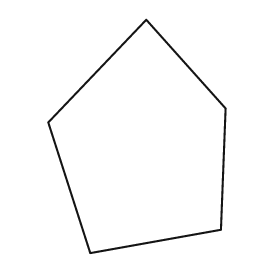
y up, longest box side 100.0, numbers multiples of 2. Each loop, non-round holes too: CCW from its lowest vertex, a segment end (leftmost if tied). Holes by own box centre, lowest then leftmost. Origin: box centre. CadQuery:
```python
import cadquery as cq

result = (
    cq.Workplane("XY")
    .moveTo(-20.0, -50.0)
    .lineTo(36.0, -40.0)
    .lineTo(38.0, 12.0)
    .lineTo(4.0, 50.0)
    .lineTo(-38.0, 6.0)
    .close()
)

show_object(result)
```